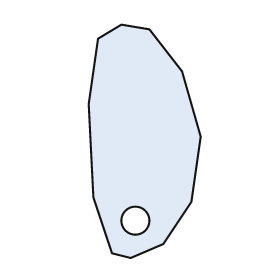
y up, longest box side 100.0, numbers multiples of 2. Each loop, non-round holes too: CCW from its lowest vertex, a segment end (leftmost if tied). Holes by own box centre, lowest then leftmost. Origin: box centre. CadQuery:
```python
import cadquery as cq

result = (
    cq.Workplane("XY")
    .moveTo(-6.0, -50.0)
    .lineTo(8.0, -44.0)
    .lineTo(20.0, -26.0)
    .lineTo(24.0, 2.0)
    .lineTo(16.0, 30.0)
    .lineTo(2.0, 48.0)
    .lineTo(-10.0, 50.0)
    .lineTo(-20.0, 44.0)
    .lineTo(-24.0, 16.0)
    .lineTo(-22.0, -24.0)
    .lineTo(-14.0, -48.0)
    .close()
    .moveTo(-4.0, -34.0)
    .circle(6.0)
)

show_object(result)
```